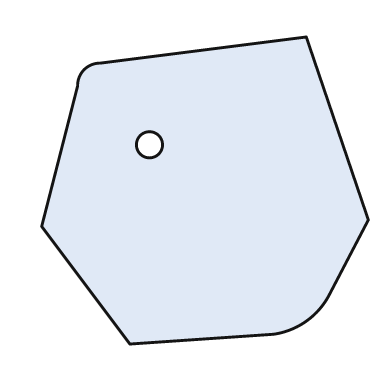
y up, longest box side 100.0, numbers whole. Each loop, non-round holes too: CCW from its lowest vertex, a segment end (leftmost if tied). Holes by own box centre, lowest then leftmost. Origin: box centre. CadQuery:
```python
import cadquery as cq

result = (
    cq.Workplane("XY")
    .moveTo(-23.0, -47.0)
    .lineTo(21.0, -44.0)
    .threePointArc((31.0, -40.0), (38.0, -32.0))
    .lineTo(50.0, -9.0)
    .lineTo(31.0, 47.0)
    .lineTo(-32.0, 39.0)
    .threePointArc((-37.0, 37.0), (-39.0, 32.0))
    .lineTo(-50.0, -11.0)
    .close()
    .moveTo(-17.0, 14.0)
    .circle(4.0)
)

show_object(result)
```